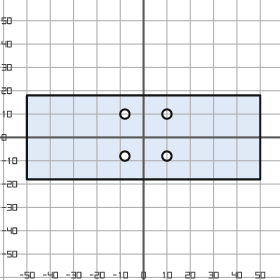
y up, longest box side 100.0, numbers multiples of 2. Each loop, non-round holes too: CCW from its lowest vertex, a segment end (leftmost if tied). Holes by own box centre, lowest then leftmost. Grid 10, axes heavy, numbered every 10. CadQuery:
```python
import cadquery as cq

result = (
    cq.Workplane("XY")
    .moveTo(-50.0, -18.0)
    .lineTo(50.0, -18.0)
    .lineTo(50.0, 18.0)
    .lineTo(-50.0, 18.0)
    .close()
    .moveTo(-8.0, -8.0)
    .circle(2.0)
    .moveTo(10.0, -8.0)
    .circle(2.0)
    .moveTo(-8.0, 10.0)
    .circle(2.0)
    .moveTo(10.0, 10.0)
    .circle(2.0)
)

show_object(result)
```